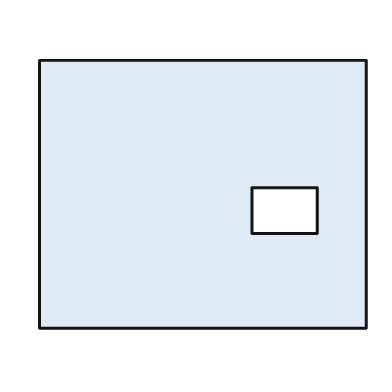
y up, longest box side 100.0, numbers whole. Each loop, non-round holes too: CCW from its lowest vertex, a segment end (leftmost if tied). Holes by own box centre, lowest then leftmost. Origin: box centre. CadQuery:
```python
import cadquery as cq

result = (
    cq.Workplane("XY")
    .moveTo(-50.0, -41.0)
    .lineTo(50.0, -41.0)
    .lineTo(50.0, 41.0)
    .lineTo(-50.0, 41.0)
    .close()
    .moveTo(15.0, -12.0)
    .lineTo(35.0, -12.0)
    .lineTo(35.0, 2.0)
    .lineTo(15.0, 2.0)
    .close()
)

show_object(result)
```